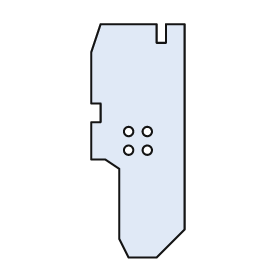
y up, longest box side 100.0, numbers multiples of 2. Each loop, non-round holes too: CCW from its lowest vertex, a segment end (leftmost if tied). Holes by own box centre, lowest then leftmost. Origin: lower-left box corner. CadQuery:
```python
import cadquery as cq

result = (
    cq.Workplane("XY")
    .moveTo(16.0, 0.0)
    .lineTo(28.0, 0.0)
    .lineTo(40.0, 12.0)
    .lineTo(40.0, 100.0)
    .lineTo(32.0, 100.0)
    .lineTo(32.0, 92.0)
    .lineTo(28.0, 92.0)
    .lineTo(28.0, 100.0)
    .lineTo(4.0, 100.0)
    .lineTo(0.0, 88.0)
    .lineTo(0.0, 66.0)
    .lineTo(4.0, 66.0)
    .lineTo(4.0, 58.0)
    .lineTo(0.0, 58.0)
    .lineTo(0.0, 42.0)
    .lineTo(6.0, 42.0)
    .lineTo(12.0, 38.0)
    .lineTo(12.0, 8.0)
    .close()
    .moveTo(16.0, 46.0)
    .circle(2.0)
    .moveTo(24.0, 46.0)
    .circle(2.0)
    .moveTo(16.0, 54.0)
    .circle(2.0)
    .moveTo(24.0, 54.0)
    .circle(2.0)
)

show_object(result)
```